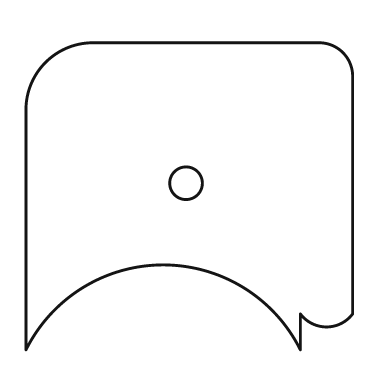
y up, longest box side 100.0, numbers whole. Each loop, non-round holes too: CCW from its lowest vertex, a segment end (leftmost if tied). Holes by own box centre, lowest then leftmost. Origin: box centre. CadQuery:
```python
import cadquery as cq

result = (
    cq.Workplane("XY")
    .moveTo(-50.0, -47.0)
    .threePointArc((-8.0, -21.0), (34.0, -47.0))
    .lineTo(34.0, -36.0)
    .threePointArc((42.0, -40.0), (50.0, -36.0))
    .lineTo(50.0, 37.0)
    .threePointArc((47.0, 44.0), (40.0, 47.0))
    .lineTo(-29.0, 47.0)
    .threePointArc((-44.0, 41.0), (-50.0, 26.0))
    .close()
    .moveTo(-1.0, 4.0)
    .circle(5.0)
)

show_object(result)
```